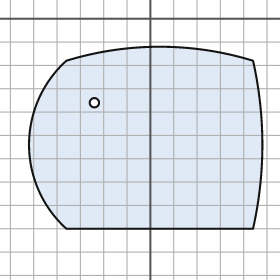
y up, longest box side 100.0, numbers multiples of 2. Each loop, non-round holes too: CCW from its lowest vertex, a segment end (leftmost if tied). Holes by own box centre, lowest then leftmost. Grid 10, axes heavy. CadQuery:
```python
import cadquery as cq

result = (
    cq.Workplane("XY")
    .moveTo(-36.0, -90.0)
    .lineTo(44.0, -90.0)
    .threePointArc((48.0, -54.0), (44.0, -18.0))
    .threePointArc((4.0, -12.0), (-36.0, -18.0))
    .threePointArc((-52.0, -54.0), (-36.0, -90.0))
    .close()
    .moveTo(-24.0, -36.0)
    .circle(2.0)
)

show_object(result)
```